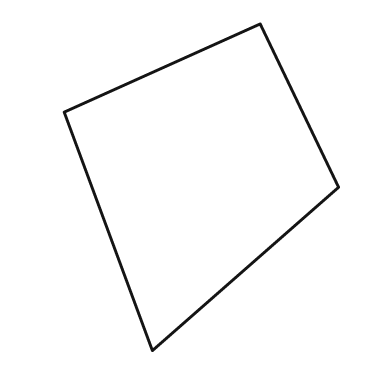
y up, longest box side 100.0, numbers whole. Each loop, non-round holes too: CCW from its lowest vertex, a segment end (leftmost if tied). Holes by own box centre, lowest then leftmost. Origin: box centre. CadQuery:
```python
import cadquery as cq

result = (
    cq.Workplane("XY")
    .moveTo(-15.0, -50.0)
    .lineTo(42.0, 0.0)
    .lineTo(18.0, 50.0)
    .lineTo(-42.0, 23.0)
    .close()
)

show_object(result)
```